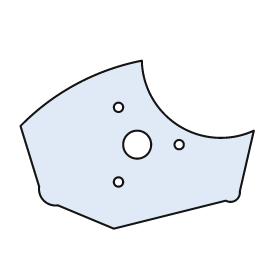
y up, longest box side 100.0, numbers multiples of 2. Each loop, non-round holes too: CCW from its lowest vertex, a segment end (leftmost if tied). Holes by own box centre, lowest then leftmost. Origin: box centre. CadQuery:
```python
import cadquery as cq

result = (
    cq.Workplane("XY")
    .moveTo(-10.0, -36.0)
    .lineTo(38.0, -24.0)
    .threePointArc((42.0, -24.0), (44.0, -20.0))
    .lineTo(50.0, 6.0)
    .threePointArc((18.0, 8.0), (2.0, 36.0))
    .threePointArc((-26.0, 26.0), (-50.0, 8.0))
    .lineTo(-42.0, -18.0)
    .threePointArc((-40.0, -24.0), (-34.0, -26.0))
    .close()
    .moveTo(-8.0, -16.0)
    .circle(2.0)
    .moveTo(0.0, 0.0)
    .circle(6.0)
    .moveTo(18.0, 0.0)
    .circle(2.0)
    .moveTo(-8.0, 16.0)
    .circle(2.0)
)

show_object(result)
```